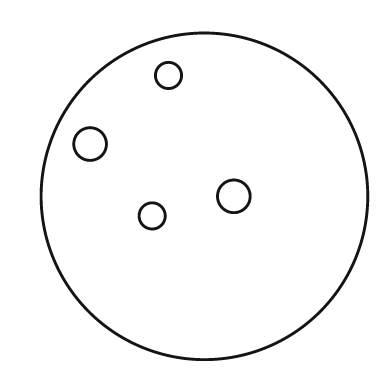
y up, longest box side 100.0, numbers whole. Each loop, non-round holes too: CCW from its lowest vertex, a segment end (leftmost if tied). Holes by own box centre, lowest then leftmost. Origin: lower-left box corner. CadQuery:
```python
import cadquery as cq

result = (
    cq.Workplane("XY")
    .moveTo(50.0, 50.0)
    .circle(50.0)
    .moveTo(34.0, 44.0)
    .circle(4.0)
    .moveTo(59.0, 50.0)
    .circle(5.0)
    .moveTo(15.0, 66.0)
    .circle(5.0)
    .moveTo(39.0, 87.0)
    .circle(4.0)
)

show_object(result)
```